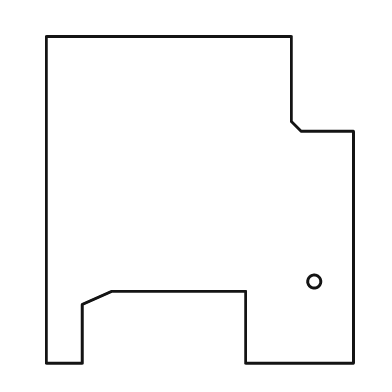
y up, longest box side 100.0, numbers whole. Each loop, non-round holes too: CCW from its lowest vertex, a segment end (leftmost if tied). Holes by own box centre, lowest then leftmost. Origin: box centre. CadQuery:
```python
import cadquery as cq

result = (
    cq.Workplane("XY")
    .moveTo(-47.0, -50.0)
    .lineTo(-36.0, -50.0)
    .lineTo(-36.0, -32.0)
    .lineTo(-27.0, -28.0)
    .lineTo(14.0, -28.0)
    .lineTo(14.0, -50.0)
    .lineTo(47.0, -50.0)
    .lineTo(47.0, 21.0)
    .lineTo(31.0, 21.0)
    .lineTo(28.0, 24.0)
    .lineTo(28.0, 50.0)
    .lineTo(-47.0, 50.0)
    .close()
    .moveTo(35.0, -25.0)
    .circle(2.0)
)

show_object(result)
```